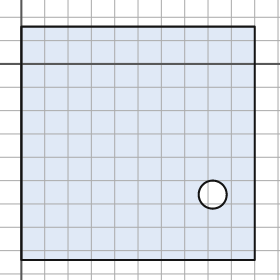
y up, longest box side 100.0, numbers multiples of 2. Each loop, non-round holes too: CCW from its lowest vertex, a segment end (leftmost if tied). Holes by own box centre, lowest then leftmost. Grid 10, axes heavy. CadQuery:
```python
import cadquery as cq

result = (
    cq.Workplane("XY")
    .moveTo(0.0, -84.0)
    .lineTo(100.0, -84.0)
    .lineTo(100.0, 16.0)
    .lineTo(0.0, 16.0)
    .close()
    .moveTo(82.0, -56.0)
    .circle(6.0)
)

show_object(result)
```